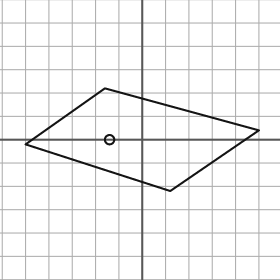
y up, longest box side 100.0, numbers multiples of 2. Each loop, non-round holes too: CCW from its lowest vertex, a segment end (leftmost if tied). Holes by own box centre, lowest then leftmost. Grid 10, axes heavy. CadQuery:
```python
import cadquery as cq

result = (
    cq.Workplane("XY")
    .moveTo(12.0, -22.0)
    .lineTo(50.0, 4.0)
    .lineTo(-16.0, 22.0)
    .lineTo(-50.0, -2.0)
    .close()
    .moveTo(-14.0, 0.0)
    .circle(2.0)
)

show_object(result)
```